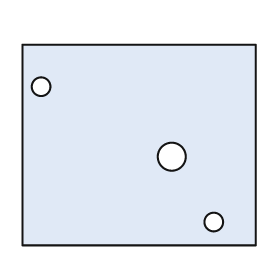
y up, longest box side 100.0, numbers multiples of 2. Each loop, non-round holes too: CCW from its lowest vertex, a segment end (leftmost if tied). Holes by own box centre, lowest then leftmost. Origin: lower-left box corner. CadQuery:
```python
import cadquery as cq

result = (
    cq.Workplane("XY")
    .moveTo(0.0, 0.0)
    .lineTo(100.0, 0.0)
    .lineTo(100.0, 86.0)
    .lineTo(0.0, 86.0)
    .close()
    .moveTo(82.0, 10.0)
    .circle(4.0)
    .moveTo(64.0, 38.0)
    .circle(6.0)
    .moveTo(8.0, 68.0)
    .circle(4.0)
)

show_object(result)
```